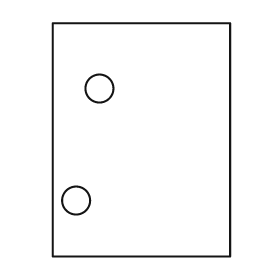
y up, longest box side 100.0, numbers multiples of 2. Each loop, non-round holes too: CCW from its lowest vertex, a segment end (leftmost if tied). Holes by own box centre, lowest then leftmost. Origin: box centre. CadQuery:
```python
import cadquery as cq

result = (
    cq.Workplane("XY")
    .moveTo(-38.0, -50.0)
    .lineTo(38.0, -50.0)
    .lineTo(38.0, 50.0)
    .lineTo(-38.0, 50.0)
    .close()
    .moveTo(-28.0, -26.0)
    .circle(6.0)
    .moveTo(-18.0, 22.0)
    .circle(6.0)
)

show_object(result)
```